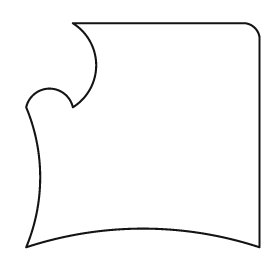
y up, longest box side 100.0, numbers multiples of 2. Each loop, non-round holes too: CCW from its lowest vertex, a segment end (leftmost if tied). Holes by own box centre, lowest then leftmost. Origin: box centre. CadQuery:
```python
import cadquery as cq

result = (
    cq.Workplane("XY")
    .moveTo(-50.0, -48.0)
    .threePointArc((0.0, -40.0), (50.0, -48.0))
    .lineTo(50.0, 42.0)
    .threePointArc((48.0, 46.0), (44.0, 48.0))
    .lineTo(-30.0, 48.0)
    .threePointArc((-20.0, 30.0), (-30.0, 12.0))
    .threePointArc((-40.0, 20.0), (-50.0, 12.0))
    .threePointArc((-44.0, -18.0), (-50.0, -48.0))
    .close()
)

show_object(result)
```